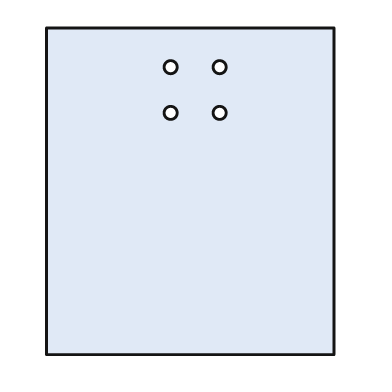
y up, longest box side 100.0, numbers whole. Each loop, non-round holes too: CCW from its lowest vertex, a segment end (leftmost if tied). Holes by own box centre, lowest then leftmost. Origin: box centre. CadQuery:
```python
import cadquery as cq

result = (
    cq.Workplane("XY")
    .moveTo(-44.0, -50.0)
    .lineTo(44.0, -50.0)
    .lineTo(44.0, 50.0)
    .lineTo(-44.0, 50.0)
    .close()
    .moveTo(-6.0, 24.0)
    .circle(2.0)
    .moveTo(9.0, 24.0)
    .circle(2.0)
    .moveTo(-6.0, 38.0)
    .circle(2.0)
    .moveTo(9.0, 38.0)
    .circle(2.0)
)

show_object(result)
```